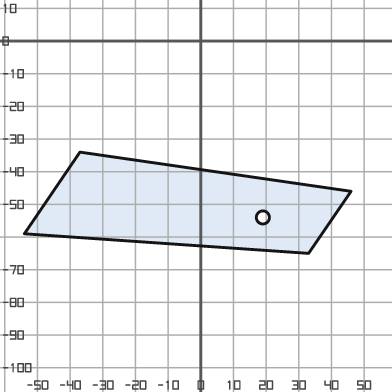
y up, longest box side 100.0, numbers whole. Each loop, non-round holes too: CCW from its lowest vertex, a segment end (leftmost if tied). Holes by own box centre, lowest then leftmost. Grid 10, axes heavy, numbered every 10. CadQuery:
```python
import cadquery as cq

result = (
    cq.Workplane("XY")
    .moveTo(33.0, -65.0)
    .lineTo(46.0, -46.0)
    .lineTo(-37.0, -34.0)
    .lineTo(-54.0, -59.0)
    .close()
    .moveTo(19.0, -54.0)
    .circle(2.0)
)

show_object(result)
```